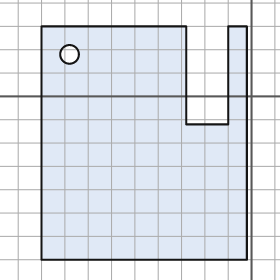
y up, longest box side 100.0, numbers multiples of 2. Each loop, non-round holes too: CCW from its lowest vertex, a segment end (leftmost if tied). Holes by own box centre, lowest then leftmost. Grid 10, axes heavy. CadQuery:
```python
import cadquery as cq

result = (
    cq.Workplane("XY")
    .moveTo(-90.0, -70.0)
    .lineTo(-2.0, -70.0)
    .lineTo(-2.0, 30.0)
    .lineTo(-10.0, 30.0)
    .lineTo(-10.0, -12.0)
    .lineTo(-28.0, -12.0)
    .lineTo(-28.0, 30.0)
    .lineTo(-90.0, 30.0)
    .close()
    .moveTo(-78.0, 18.0)
    .circle(4.0)
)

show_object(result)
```